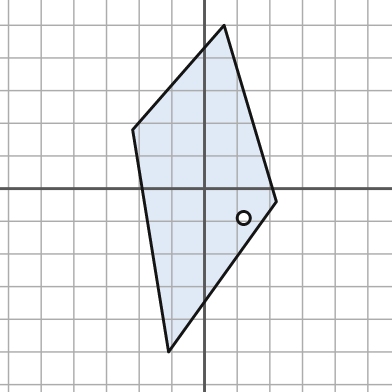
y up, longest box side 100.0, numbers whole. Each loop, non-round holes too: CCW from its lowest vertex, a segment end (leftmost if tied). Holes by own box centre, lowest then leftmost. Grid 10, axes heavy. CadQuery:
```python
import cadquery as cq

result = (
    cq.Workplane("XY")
    .moveTo(-11.0, -50.0)
    .lineTo(22.0, -4.0)
    .lineTo(6.0, 50.0)
    .lineTo(-22.0, 18.0)
    .close()
    .moveTo(12.0, -9.0)
    .circle(2.0)
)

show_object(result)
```